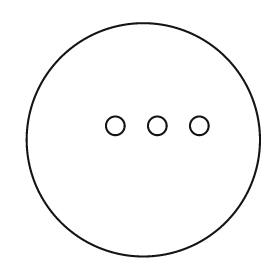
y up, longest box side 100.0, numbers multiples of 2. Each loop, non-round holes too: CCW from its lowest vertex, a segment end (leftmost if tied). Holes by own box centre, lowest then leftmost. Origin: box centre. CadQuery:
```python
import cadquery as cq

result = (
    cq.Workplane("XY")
    .moveTo(0.0, 0.0)
    .circle(50.0)
    .moveTo(-12.0, 6.0)
    .circle(4.0)
    .moveTo(6.0, 6.0)
    .circle(4.0)
    .moveTo(24.0, 6.0)
    .circle(4.0)
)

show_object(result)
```